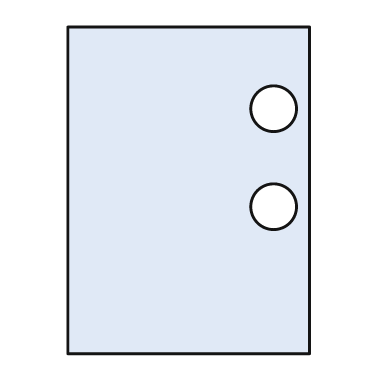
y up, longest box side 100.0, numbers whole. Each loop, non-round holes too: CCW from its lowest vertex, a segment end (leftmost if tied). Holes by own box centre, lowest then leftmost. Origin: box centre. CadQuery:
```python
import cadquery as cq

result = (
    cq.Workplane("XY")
    .moveTo(-37.0, -50.0)
    .lineTo(37.0, -50.0)
    .lineTo(37.0, 50.0)
    .lineTo(-37.0, 50.0)
    .close()
    .moveTo(26.0, -5.0)
    .circle(7.0)
    .moveTo(26.0, 25.0)
    .circle(7.0)
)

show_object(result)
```